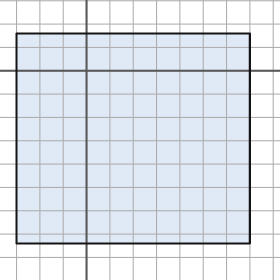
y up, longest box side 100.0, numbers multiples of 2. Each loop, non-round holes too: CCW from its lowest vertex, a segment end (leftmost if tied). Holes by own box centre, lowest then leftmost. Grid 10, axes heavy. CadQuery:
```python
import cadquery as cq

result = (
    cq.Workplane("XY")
    .moveTo(-30.0, -74.0)
    .lineTo(70.0, -74.0)
    .lineTo(70.0, 16.0)
    .lineTo(-30.0, 16.0)
    .close()
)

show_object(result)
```